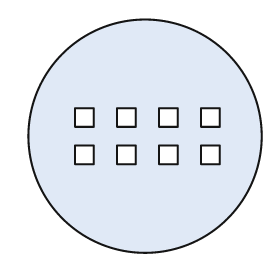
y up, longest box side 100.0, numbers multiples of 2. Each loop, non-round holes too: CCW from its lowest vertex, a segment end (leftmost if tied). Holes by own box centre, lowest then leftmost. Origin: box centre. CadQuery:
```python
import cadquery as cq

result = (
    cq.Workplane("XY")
    .moveTo(0.0, 0.0)
    .circle(50.0)
    .moveTo(-30.0, -12.0)
    .lineTo(-22.0, -12.0)
    .lineTo(-22.0, -4.0)
    .lineTo(-30.0, -4.0)
    .close()
    .moveTo(-12.0, -12.0)
    .lineTo(-4.0, -12.0)
    .lineTo(-4.0, -4.0)
    .lineTo(-12.0, -4.0)
    .close()
    .moveTo(6.0, -12.0)
    .lineTo(14.0, -12.0)
    .lineTo(14.0, -4.0)
    .lineTo(6.0, -4.0)
    .close()
    .moveTo(24.0, -12.0)
    .lineTo(32.0, -12.0)
    .lineTo(32.0, -4.0)
    .lineTo(24.0, -4.0)
    .close()
    .moveTo(-30.0, 4.0)
    .lineTo(-22.0, 4.0)
    .lineTo(-22.0, 12.0)
    .lineTo(-30.0, 12.0)
    .close()
    .moveTo(-12.0, 4.0)
    .lineTo(-4.0, 4.0)
    .lineTo(-4.0, 12.0)
    .lineTo(-12.0, 12.0)
    .close()
    .moveTo(6.0, 4.0)
    .lineTo(14.0, 4.0)
    .lineTo(14.0, 12.0)
    .lineTo(6.0, 12.0)
    .close()
    .moveTo(24.0, 4.0)
    .lineTo(32.0, 4.0)
    .lineTo(32.0, 12.0)
    .lineTo(24.0, 12.0)
    .close()
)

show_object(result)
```